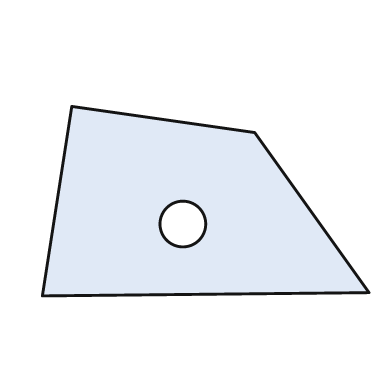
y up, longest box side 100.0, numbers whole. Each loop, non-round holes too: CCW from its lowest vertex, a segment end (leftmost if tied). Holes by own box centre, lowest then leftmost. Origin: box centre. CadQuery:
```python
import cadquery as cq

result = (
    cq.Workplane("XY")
    .moveTo(-50.0, -29.0)
    .lineTo(50.0, -28.0)
    .lineTo(15.0, 21.0)
    .lineTo(-41.0, 29.0)
    .close()
    .moveTo(-7.0, -7.0)
    .circle(7.0)
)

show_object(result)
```